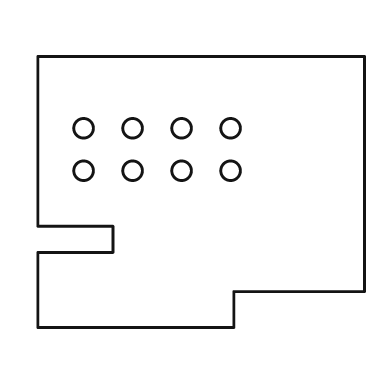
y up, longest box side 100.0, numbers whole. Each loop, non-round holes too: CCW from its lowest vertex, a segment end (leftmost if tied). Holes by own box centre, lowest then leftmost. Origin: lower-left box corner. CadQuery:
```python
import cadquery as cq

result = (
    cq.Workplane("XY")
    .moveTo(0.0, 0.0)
    .lineTo(60.0, 0.0)
    .lineTo(60.0, 11.0)
    .lineTo(100.0, 11.0)
    .lineTo(100.0, 83.0)
    .lineTo(0.0, 83.0)
    .lineTo(0.0, 31.0)
    .lineTo(23.0, 31.0)
    .lineTo(23.0, 23.0)
    .lineTo(0.0, 23.0)
    .close()
    .moveTo(14.0, 48.0)
    .circle(3.0)
    .moveTo(29.0, 48.0)
    .circle(3.0)
    .moveTo(44.0, 48.0)
    .circle(3.0)
    .moveTo(59.0, 48.0)
    .circle(3.0)
    .moveTo(14.0, 61.0)
    .circle(3.0)
    .moveTo(29.0, 61.0)
    .circle(3.0)
    .moveTo(44.0, 61.0)
    .circle(3.0)
    .moveTo(59.0, 61.0)
    .circle(3.0)
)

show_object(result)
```